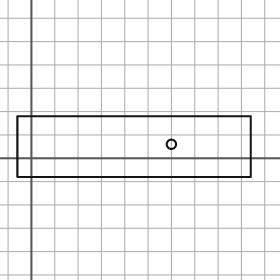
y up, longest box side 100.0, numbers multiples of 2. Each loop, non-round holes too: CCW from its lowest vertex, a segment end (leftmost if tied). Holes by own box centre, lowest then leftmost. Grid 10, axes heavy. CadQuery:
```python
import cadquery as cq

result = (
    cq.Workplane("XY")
    .moveTo(-6.0, -8.0)
    .lineTo(94.0, -8.0)
    .lineTo(94.0, 18.0)
    .lineTo(-6.0, 18.0)
    .close()
    .moveTo(60.0, 6.0)
    .circle(2.0)
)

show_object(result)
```